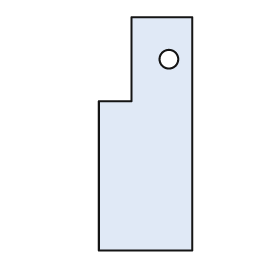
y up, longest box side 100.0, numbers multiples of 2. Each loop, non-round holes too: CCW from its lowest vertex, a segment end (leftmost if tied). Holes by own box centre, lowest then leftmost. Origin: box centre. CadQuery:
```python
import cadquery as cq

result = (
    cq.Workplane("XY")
    .moveTo(-20.0, -50.0)
    .lineTo(20.0, -50.0)
    .lineTo(20.0, 50.0)
    .lineTo(-6.0, 50.0)
    .lineTo(-6.0, 14.0)
    .lineTo(-20.0, 14.0)
    .close()
    .moveTo(10.0, 32.0)
    .circle(4.0)
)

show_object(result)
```